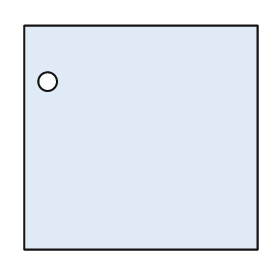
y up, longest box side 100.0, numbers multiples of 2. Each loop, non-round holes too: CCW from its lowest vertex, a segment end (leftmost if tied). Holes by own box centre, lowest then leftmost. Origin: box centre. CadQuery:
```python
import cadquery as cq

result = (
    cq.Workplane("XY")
    .moveTo(-50.0, -48.0)
    .lineTo(50.0, -48.0)
    .lineTo(50.0, 48.0)
    .lineTo(-50.0, 48.0)
    .close()
    .moveTo(-40.0, 24.0)
    .circle(4.0)
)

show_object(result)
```